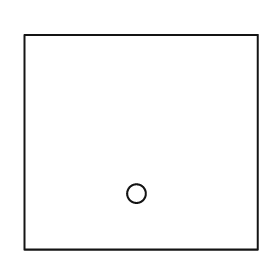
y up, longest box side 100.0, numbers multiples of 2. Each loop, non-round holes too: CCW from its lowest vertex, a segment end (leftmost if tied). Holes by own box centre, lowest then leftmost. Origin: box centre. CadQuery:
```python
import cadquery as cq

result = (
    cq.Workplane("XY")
    .moveTo(-50.0, -46.0)
    .lineTo(50.0, -46.0)
    .lineTo(50.0, 46.0)
    .lineTo(-50.0, 46.0)
    .close()
    .moveTo(-2.0, -22.0)
    .circle(4.0)
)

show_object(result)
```